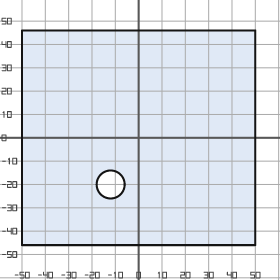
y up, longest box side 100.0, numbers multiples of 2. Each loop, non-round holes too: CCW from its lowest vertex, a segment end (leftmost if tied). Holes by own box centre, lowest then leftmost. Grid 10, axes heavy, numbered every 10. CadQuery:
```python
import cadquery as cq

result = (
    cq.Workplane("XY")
    .moveTo(-50.0, -46.0)
    .lineTo(50.0, -46.0)
    .lineTo(50.0, 46.0)
    .lineTo(-50.0, 46.0)
    .close()
    .moveTo(-12.0, -20.0)
    .circle(6.0)
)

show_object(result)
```